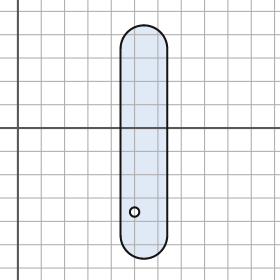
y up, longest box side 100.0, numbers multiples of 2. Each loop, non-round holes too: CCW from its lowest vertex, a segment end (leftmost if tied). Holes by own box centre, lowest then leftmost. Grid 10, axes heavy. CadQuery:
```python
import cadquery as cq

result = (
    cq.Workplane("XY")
    .moveTo(44.0, -46.0)
    .threePointArc((54.0, -56.0), (64.0, -46.0))
    .lineTo(64.0, 34.0)
    .threePointArc((54.0, 44.0), (44.0, 34.0))
    .close()
    .moveTo(50.0, -36.0)
    .circle(2.0)
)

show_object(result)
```